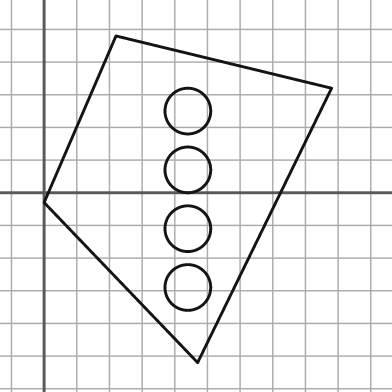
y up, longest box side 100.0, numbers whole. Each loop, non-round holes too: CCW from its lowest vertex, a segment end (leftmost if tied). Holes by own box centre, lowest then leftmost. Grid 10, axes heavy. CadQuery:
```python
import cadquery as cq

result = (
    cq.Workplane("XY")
    .moveTo(47.0, -52.0)
    .lineTo(88.0, 32.0)
    .lineTo(22.0, 48.0)
    .lineTo(0.0, -3.0)
    .close()
    .moveTo(44.0, -29.0)
    .circle(7.0)
    .moveTo(44.0, -11.0)
    .circle(7.0)
    .moveTo(44.0, 7.0)
    .circle(7.0)
    .moveTo(44.0, 25.0)
    .circle(7.0)
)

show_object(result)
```